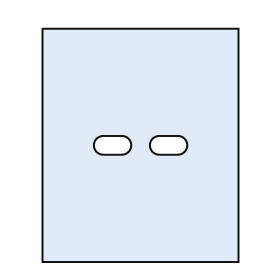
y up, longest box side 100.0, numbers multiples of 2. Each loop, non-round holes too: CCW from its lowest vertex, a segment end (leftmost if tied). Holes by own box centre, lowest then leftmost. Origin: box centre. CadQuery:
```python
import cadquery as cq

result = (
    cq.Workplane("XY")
    .moveTo(-42.0, -50.0)
    .lineTo(42.0, -50.0)
    .lineTo(42.0, 50.0)
    .lineTo(-42.0, 50.0)
    .close()
    .moveTo(-16.0, -4.0)
    .lineTo(-8.0, -4.0)
    .threePointArc((-4.0, 0.0), (-8.0, 4.0))
    .lineTo(-16.0, 4.0)
    .threePointArc((-20.0, 0.0), (-16.0, -4.0))
    .close()
    .moveTo(8.0, -4.0)
    .lineTo(16.0, -4.0)
    .threePointArc((20.0, 0.0), (16.0, 4.0))
    .lineTo(8.0, 4.0)
    .threePointArc((4.0, 0.0), (8.0, -4.0))
    .close()
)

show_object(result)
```